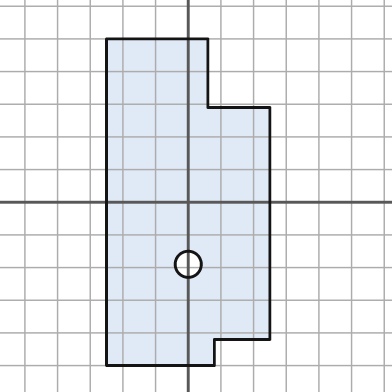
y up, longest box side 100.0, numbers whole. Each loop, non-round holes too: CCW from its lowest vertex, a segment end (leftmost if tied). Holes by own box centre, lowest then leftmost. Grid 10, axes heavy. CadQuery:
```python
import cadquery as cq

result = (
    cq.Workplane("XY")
    .moveTo(-25.0, -50.0)
    .lineTo(8.0, -50.0)
    .lineTo(8.0, -42.0)
    .lineTo(25.0, -42.0)
    .lineTo(25.0, 29.0)
    .lineTo(6.0, 29.0)
    .lineTo(6.0, 50.0)
    .lineTo(-25.0, 50.0)
    .close()
    .moveTo(0.0, -19.0)
    .circle(4.0)
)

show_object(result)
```